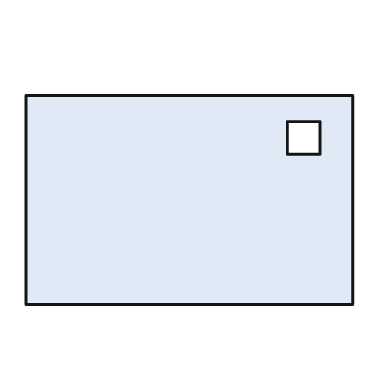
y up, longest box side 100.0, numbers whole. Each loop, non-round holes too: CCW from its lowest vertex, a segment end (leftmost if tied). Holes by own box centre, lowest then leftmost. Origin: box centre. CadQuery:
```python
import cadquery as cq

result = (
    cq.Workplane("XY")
    .moveTo(-50.0, -32.0)
    .lineTo(50.0, -32.0)
    .lineTo(50.0, 32.0)
    .lineTo(-50.0, 32.0)
    .close()
    .moveTo(30.0, 14.0)
    .lineTo(40.0, 14.0)
    .lineTo(40.0, 24.0)
    .lineTo(30.0, 24.0)
    .close()
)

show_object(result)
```